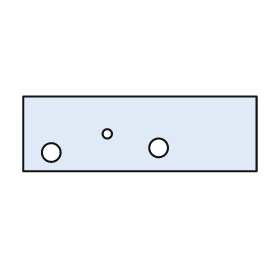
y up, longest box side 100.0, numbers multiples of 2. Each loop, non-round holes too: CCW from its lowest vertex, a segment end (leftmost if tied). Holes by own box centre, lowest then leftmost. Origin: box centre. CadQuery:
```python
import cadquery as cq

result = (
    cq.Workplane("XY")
    .moveTo(-50.0, -16.0)
    .lineTo(50.0, -16.0)
    .lineTo(50.0, 16.0)
    .lineTo(-50.0, 16.0)
    .close()
    .moveTo(-38.0, -8.0)
    .circle(4.0)
    .moveTo(8.0, -6.0)
    .circle(4.0)
    .moveTo(-14.0, 0.0)
    .circle(2.0)
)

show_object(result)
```